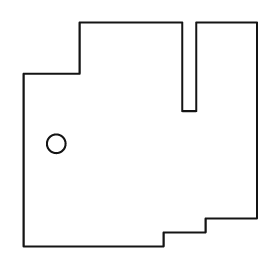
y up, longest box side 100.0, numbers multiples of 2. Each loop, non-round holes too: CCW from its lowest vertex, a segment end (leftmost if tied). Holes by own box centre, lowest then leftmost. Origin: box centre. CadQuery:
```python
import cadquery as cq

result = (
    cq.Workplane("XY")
    .moveTo(-50.0, -48.0)
    .lineTo(10.0, -48.0)
    .lineTo(10.0, -42.0)
    .lineTo(28.0, -42.0)
    .lineTo(28.0, -36.0)
    .lineTo(50.0, -36.0)
    .lineTo(50.0, 48.0)
    .lineTo(24.0, 48.0)
    .lineTo(24.0, 10.0)
    .lineTo(18.0, 10.0)
    .lineTo(18.0, 48.0)
    .lineTo(-26.0, 48.0)
    .lineTo(-26.0, 26.0)
    .lineTo(-50.0, 26.0)
    .close()
    .moveTo(-36.0, -4.0)
    .circle(4.0)
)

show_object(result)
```